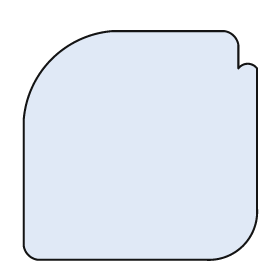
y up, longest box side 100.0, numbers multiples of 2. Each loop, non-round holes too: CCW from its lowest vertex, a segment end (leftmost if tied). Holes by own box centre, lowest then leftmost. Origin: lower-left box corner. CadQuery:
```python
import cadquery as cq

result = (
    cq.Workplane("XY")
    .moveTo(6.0, 0.0)
    .lineTo(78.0, 0.0)
    .threePointArc((94.0, 6.0), (100.0, 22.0))
    .lineTo(100.0, 82.0)
    .threePointArc((96.0, 84.0), (92.0, 82.0))
    .lineTo(92.0, 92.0)
    .threePointArc((90.0, 96.0), (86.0, 98.0))
    .lineTo(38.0, 98.0)
    .threePointArc((12.0, 86.0), (0.0, 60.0))
    .lineTo(0.0, 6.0)
    .threePointArc((2.0, 2.0), (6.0, 0.0))
    .close()
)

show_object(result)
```